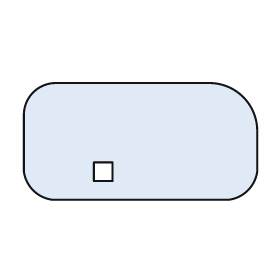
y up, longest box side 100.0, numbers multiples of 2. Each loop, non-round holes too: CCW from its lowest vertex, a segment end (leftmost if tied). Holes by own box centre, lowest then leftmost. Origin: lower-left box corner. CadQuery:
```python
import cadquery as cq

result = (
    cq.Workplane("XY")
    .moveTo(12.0, 0.0)
    .lineTo(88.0, 0.0)
    .threePointArc((96.0, 4.0), (100.0, 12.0))
    .lineTo(100.0, 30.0)
    .threePointArc((94.0, 44.0), (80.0, 50.0))
    .lineTo(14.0, 50.0)
    .threePointArc((4.0, 46.0), (0.0, 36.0))
    .lineTo(0.0, 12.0)
    .threePointArc((4.0, 4.0), (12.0, 0.0))
    .close()
    .moveTo(30.0, 8.0)
    .lineTo(38.0, 8.0)
    .lineTo(38.0, 16.0)
    .lineTo(30.0, 16.0)
    .close()
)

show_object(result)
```